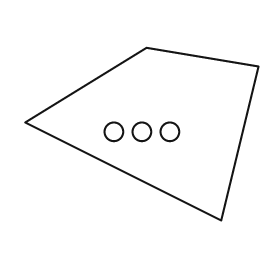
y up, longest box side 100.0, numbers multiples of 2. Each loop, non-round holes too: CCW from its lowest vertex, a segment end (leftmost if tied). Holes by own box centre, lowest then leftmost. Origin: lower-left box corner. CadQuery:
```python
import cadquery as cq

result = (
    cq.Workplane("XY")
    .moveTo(84.0, 0.0)
    .lineTo(100.0, 66.0)
    .lineTo(52.0, 74.0)
    .lineTo(0.0, 42.0)
    .close()
    .moveTo(38.0, 38.0)
    .circle(4.0)
    .moveTo(50.0, 38.0)
    .circle(4.0)
    .moveTo(62.0, 38.0)
    .circle(4.0)
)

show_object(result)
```